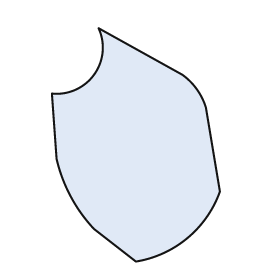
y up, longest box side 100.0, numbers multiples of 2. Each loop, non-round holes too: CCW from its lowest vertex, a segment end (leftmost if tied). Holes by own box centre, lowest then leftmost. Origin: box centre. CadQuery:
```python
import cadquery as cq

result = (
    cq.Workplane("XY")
    .moveTo(0.0, -50.0)
    .threePointArc((22.0, -40.0), (36.0, -20.0))
    .lineTo(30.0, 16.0)
    .threePointArc((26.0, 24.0), (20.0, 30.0))
    .lineTo(-16.0, 50.0)
    .threePointArc((-18.0, 30.0), (-36.0, 22.0))
    .lineTo(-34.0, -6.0)
    .threePointArc((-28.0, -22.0), (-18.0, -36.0))
    .close()
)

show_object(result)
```